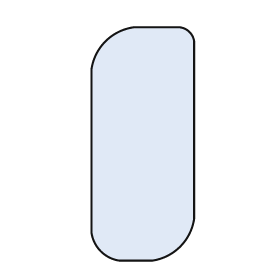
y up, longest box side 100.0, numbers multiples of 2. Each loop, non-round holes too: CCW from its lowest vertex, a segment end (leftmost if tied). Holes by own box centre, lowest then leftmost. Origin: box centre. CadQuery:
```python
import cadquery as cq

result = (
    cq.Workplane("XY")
    .moveTo(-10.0, -50.0)
    .lineTo(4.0, -50.0)
    .threePointArc((16.0, -44.0), (22.0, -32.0))
    .lineTo(22.0, 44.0)
    .threePointArc((20.0, 48.0), (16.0, 50.0))
    .lineTo(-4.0, 50.0)
    .threePointArc((-16.0, 44.0), (-22.0, 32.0))
    .lineTo(-22.0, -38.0)
    .threePointArc((-18.0, -46.0), (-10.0, -50.0))
    .close()
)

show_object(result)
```